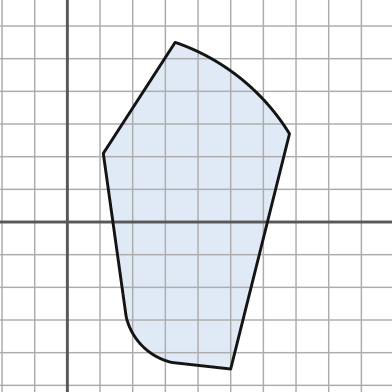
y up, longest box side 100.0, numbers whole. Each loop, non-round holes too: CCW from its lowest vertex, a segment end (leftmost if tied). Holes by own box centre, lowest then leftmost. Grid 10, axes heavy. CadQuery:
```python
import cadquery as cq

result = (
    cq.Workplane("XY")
    .moveTo(50.0, -45.0)
    .lineTo(68.0, 27.0)
    .threePointArc((53.0, 44.0), (33.0, 55.0))
    .lineTo(11.0, 21.0)
    .lineTo(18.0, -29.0)
    .threePointArc((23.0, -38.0), (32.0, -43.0))
    .close()
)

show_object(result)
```